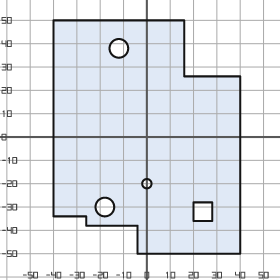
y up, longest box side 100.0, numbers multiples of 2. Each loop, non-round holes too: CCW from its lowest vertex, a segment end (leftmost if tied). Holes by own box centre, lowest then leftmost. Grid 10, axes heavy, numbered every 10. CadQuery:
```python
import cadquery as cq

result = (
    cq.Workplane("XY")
    .moveTo(-4.0, -50.0)
    .lineTo(40.0, -50.0)
    .lineTo(40.0, 26.0)
    .lineTo(16.0, 26.0)
    .lineTo(16.0, 50.0)
    .lineTo(-40.0, 50.0)
    .lineTo(-40.0, -34.0)
    .lineTo(-26.0, -34.0)
    .lineTo(-26.0, -38.0)
    .lineTo(-4.0, -38.0)
    .close()
    .moveTo(20.0, -36.0)
    .lineTo(28.0, -36.0)
    .lineTo(28.0, -28.0)
    .lineTo(20.0, -28.0)
    .close()
    .moveTo(-18.0, -30.0)
    .circle(4.0)
    .moveTo(0.0, -20.0)
    .circle(2.0)
    .moveTo(-12.0, 38.0)
    .circle(4.0)
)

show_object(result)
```